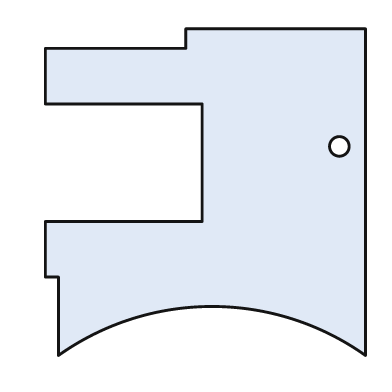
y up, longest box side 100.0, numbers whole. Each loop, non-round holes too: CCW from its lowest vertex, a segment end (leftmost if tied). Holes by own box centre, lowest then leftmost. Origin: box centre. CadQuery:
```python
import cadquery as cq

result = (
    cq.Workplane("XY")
    .moveTo(-45.0, -50.0)
    .threePointArc((2.0, -35.0), (49.0, -50.0))
    .lineTo(49.0, 50.0)
    .lineTo(-6.0, 50.0)
    .lineTo(-6.0, 44.0)
    .lineTo(-49.0, 44.0)
    .lineTo(-49.0, 27.0)
    .lineTo(-1.0, 27.0)
    .lineTo(-1.0, -9.0)
    .lineTo(-49.0, -9.0)
    .lineTo(-49.0, -26.0)
    .lineTo(-45.0, -26.0)
    .close()
    .moveTo(41.0, 14.0)
    .circle(3.0)
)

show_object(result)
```